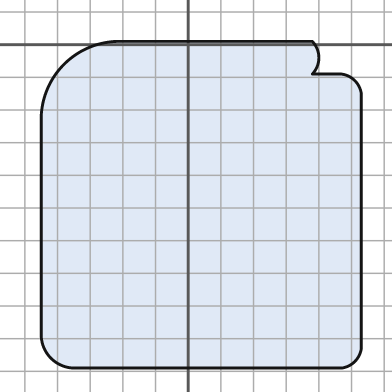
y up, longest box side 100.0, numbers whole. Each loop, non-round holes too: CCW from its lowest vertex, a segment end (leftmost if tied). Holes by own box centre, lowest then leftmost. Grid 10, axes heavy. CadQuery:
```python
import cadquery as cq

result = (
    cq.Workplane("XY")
    .moveTo(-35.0, -99.0)
    .lineTo(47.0, -99.0)
    .threePointArc((51.0, -97.0), (53.0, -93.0))
    .lineTo(53.0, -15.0)
    .threePointArc((51.0, -11.0), (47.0, -9.0))
    .lineTo(38.0, -9.0)
    .threePointArc((40.0, -4.0), (38.0, 1.0))
    .lineTo(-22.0, 1.0)
    .threePointArc((-38.0, -6.0), (-45.0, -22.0))
    .lineTo(-45.0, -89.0)
    .threePointArc((-42.0, -96.0), (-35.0, -99.0))
    .close()
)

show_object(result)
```